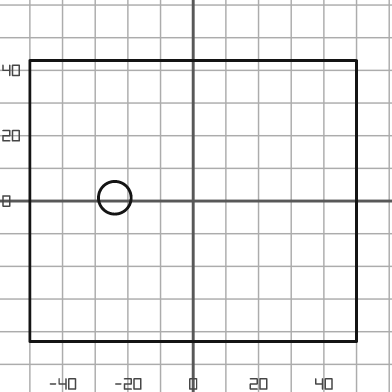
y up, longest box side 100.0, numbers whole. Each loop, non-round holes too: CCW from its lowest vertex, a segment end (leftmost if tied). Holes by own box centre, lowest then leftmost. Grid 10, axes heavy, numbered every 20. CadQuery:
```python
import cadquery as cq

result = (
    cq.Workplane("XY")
    .moveTo(-50.0, -43.0)
    .lineTo(50.0, -43.0)
    .lineTo(50.0, 43.0)
    .lineTo(-50.0, 43.0)
    .close()
    .moveTo(-24.0, 1.0)
    .circle(5.0)
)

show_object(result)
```